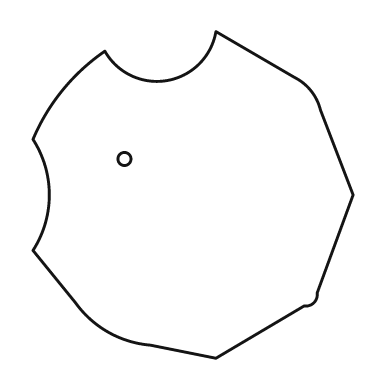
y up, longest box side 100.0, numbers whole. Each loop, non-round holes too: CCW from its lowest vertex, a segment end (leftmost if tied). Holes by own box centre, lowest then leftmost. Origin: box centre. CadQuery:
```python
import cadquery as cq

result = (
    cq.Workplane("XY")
    .moveTo(7.0, -50.0)
    .lineTo(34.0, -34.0)
    .threePointArc((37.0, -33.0), (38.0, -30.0))
    .lineTo(49.0, 0.0)
    .lineTo(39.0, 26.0)
    .threePointArc((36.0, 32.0), (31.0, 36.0))
    .lineTo(7.0, 50.0)
    .threePointArc((-8.0, 35.0), (-27.0, 44.0))
    .threePointArc((-40.0, 32.0), (-49.0, 17.0))
    .threePointArc((-44.0, 0.0), (-49.0, -17.0))
    .lineTo(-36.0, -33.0)
    .threePointArc((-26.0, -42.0), (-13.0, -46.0))
    .close()
    .moveTo(-21.0, 11.0)
    .circle(2.0)
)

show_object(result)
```